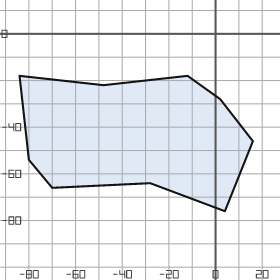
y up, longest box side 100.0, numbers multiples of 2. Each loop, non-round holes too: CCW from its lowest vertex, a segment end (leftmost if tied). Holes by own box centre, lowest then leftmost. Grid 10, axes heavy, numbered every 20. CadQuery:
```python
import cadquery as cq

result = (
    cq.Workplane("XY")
    .moveTo(4.0, -76.0)
    .lineTo(16.0, -46.0)
    .lineTo(2.0, -28.0)
    .lineTo(-12.0, -18.0)
    .lineTo(-48.0, -22.0)
    .lineTo(-84.0, -18.0)
    .lineTo(-80.0, -54.0)
    .lineTo(-70.0, -66.0)
    .lineTo(-28.0, -64.0)
    .close()
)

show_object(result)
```